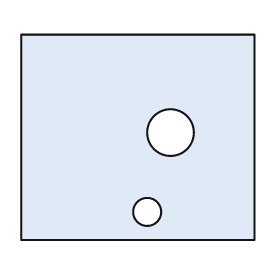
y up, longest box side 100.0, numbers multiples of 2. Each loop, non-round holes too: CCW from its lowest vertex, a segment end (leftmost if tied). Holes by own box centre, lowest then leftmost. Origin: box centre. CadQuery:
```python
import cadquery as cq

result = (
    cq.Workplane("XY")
    .moveTo(-50.0, -44.0)
    .lineTo(50.0, -44.0)
    .lineTo(50.0, 44.0)
    .lineTo(-50.0, 44.0)
    .close()
    .moveTo(4.0, -32.0)
    .circle(6.0)
    .moveTo(14.0, 2.0)
    .circle(10.0)
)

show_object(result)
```